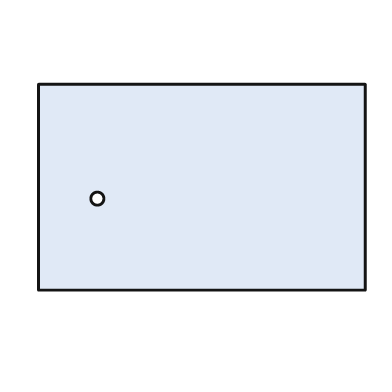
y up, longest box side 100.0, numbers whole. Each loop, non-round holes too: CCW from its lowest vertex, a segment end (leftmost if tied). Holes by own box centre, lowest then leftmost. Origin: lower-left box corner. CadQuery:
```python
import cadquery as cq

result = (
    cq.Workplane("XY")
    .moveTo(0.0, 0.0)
    .lineTo(100.0, 0.0)
    .lineTo(100.0, 63.0)
    .lineTo(0.0, 63.0)
    .close()
    .moveTo(18.0, 28.0)
    .circle(2.0)
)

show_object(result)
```